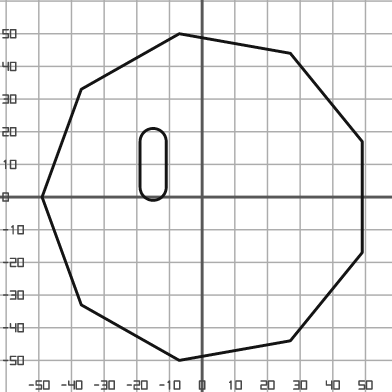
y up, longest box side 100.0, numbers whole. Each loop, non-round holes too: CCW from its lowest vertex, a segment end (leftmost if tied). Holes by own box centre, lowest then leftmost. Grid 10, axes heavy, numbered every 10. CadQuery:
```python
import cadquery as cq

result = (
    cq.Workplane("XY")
    .moveTo(-7.0, -50.0)
    .lineTo(27.0, -44.0)
    .lineTo(49.0, -17.0)
    .lineTo(49.0, 17.0)
    .lineTo(27.0, 44.0)
    .lineTo(-7.0, 50.0)
    .lineTo(-37.0, 33.0)
    .lineTo(-49.0, 0.0)
    .lineTo(-37.0, -33.0)
    .close()
    .moveTo(-19.0, 3.0)
    .threePointArc((-15.0, -1.0), (-11.0, 3.0))
    .lineTo(-11.0, 17.0)
    .threePointArc((-15.0, 21.0), (-19.0, 17.0))
    .close()
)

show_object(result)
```